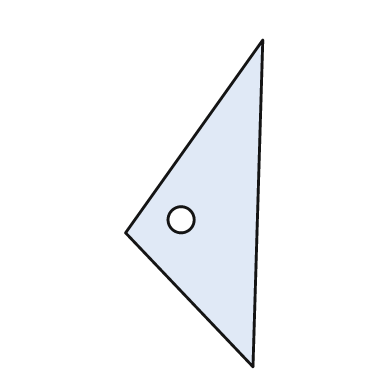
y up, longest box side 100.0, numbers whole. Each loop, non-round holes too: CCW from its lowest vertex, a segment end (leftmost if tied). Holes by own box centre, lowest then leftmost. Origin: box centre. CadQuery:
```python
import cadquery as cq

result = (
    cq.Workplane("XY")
    .moveTo(18.0, -50.0)
    .lineTo(21.0, 50.0)
    .lineTo(-21.0, -9.0)
    .close()
    .moveTo(-4.0, -5.0)
    .circle(4.0)
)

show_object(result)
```